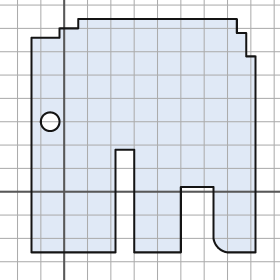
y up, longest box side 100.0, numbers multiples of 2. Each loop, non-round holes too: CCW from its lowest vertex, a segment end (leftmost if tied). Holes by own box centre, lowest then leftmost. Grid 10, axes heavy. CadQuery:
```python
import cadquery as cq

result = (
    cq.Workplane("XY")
    .moveTo(-14.0, -26.0)
    .lineTo(22.0, -26.0)
    .lineTo(22.0, 18.0)
    .lineTo(30.0, 18.0)
    .lineTo(30.0, -26.0)
    .lineTo(50.0, -26.0)
    .lineTo(50.0, 2.0)
    .lineTo(64.0, 2.0)
    .lineTo(64.0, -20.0)
    .threePointArc((66.0, -24.0), (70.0, -26.0))
    .lineTo(82.0, -26.0)
    .lineTo(82.0, 58.0)
    .lineTo(78.0, 58.0)
    .lineTo(78.0, 68.0)
    .lineTo(74.0, 68.0)
    .lineTo(74.0, 74.0)
    .lineTo(6.0, 74.0)
    .lineTo(6.0, 70.0)
    .lineTo(-2.0, 70.0)
    .lineTo(-2.0, 66.0)
    .lineTo(-14.0, 66.0)
    .close()
    .moveTo(-6.0, 30.0)
    .circle(4.0)
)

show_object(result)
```